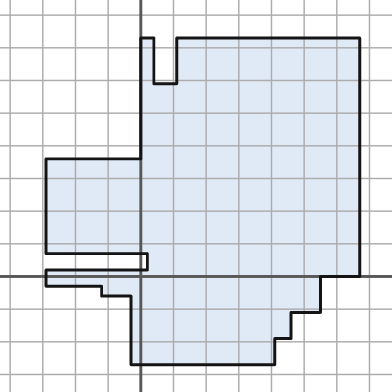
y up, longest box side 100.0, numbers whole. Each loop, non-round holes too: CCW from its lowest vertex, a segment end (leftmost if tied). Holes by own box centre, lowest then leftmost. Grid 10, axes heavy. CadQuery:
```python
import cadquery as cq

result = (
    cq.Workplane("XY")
    .moveTo(-3.0, -27.0)
    .lineTo(41.0, -27.0)
    .lineTo(41.0, -19.0)
    .lineTo(46.0, -19.0)
    .lineTo(46.0, -11.0)
    .lineTo(55.0, -11.0)
    .lineTo(55.0, 0.0)
    .lineTo(67.0, 0.0)
    .lineTo(67.0, 73.0)
    .lineTo(11.0, 73.0)
    .lineTo(11.0, 59.0)
    .lineTo(4.0, 59.0)
    .lineTo(4.0, 73.0)
    .lineTo(0.0, 73.0)
    .lineTo(0.0, 36.0)
    .lineTo(-29.0, 36.0)
    .lineTo(-29.0, 7.0)
    .lineTo(2.0, 7.0)
    .lineTo(2.0, 2.0)
    .lineTo(-29.0, 2.0)
    .lineTo(-29.0, -3.0)
    .lineTo(-12.0, -3.0)
    .lineTo(-12.0, -6.0)
    .lineTo(-3.0, -6.0)
    .close()
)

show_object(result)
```